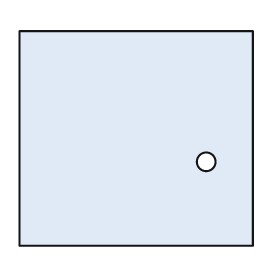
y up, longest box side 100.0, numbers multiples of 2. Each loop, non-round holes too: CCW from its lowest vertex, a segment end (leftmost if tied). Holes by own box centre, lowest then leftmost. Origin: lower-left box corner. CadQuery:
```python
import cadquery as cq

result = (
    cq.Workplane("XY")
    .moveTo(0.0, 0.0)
    .lineTo(100.0, 0.0)
    .lineTo(100.0, 92.0)
    .lineTo(0.0, 92.0)
    .close()
    .moveTo(80.0, 36.0)
    .circle(4.0)
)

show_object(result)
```